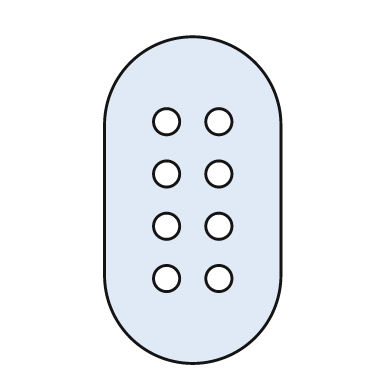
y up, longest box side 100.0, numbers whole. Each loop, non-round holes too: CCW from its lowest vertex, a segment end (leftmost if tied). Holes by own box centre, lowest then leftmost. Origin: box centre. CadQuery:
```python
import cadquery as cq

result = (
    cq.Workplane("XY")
    .moveTo(-27.0, -23.0)
    .threePointArc((0.0, -50.0), (27.0, -23.0))
    .lineTo(27.0, 23.0)
    .threePointArc((0.0, 50.0), (-27.0, 23.0))
    .close()
    .moveTo(-8.0, -24.0)
    .circle(4.0)
    .moveTo(8.0, -24.0)
    .circle(4.0)
    .moveTo(-8.0, -8.0)
    .circle(4.0)
    .moveTo(8.0, -8.0)
    .circle(4.0)
    .moveTo(-8.0, 8.0)
    .circle(4.0)
    .moveTo(8.0, 8.0)
    .circle(4.0)
    .moveTo(-8.0, 24.0)
    .circle(4.0)
    .moveTo(8.0, 24.0)
    .circle(4.0)
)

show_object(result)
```